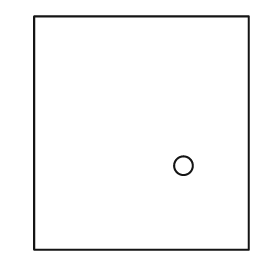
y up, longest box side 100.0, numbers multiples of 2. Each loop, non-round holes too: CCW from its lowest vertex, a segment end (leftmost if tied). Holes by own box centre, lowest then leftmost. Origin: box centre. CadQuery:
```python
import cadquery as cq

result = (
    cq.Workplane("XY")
    .moveTo(-46.0, -50.0)
    .lineTo(46.0, -50.0)
    .lineTo(46.0, 50.0)
    .lineTo(-46.0, 50.0)
    .close()
    .moveTo(18.0, -14.0)
    .circle(4.0)
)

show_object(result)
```